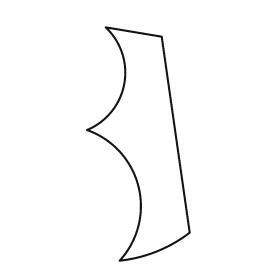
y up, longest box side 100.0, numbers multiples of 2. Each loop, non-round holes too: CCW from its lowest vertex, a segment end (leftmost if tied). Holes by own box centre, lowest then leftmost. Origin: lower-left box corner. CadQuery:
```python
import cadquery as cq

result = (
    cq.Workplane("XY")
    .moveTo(14.0, 0.0)
    .threePointArc((30.0, 4.0), (44.0, 12.0))
    .lineTo(32.0, 96.0)
    .lineTo(8.0, 100.0)
    .threePointArc((16.0, 76.0), (0.0, 56.0))
    .threePointArc((22.0, 32.0), (14.0, 0.0))
    .close()
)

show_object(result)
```